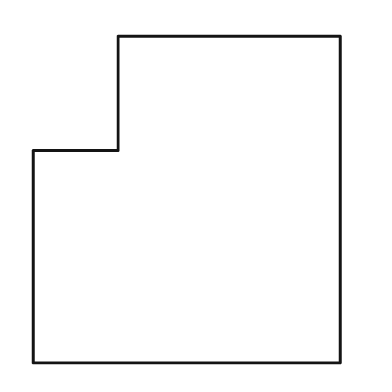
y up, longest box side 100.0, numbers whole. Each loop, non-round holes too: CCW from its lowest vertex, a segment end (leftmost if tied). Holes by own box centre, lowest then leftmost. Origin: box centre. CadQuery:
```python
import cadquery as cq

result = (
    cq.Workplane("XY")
    .moveTo(-47.0, -50.0)
    .lineTo(47.0, -50.0)
    .lineTo(47.0, 50.0)
    .lineTo(-21.0, 50.0)
    .lineTo(-21.0, 15.0)
    .lineTo(-47.0, 15.0)
    .close()
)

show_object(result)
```